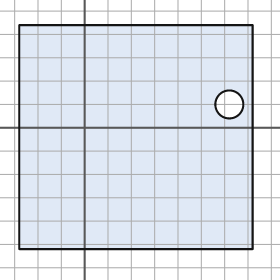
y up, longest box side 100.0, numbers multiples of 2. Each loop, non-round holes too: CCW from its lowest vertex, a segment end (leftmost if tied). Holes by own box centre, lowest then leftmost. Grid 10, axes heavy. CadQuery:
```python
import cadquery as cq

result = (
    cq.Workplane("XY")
    .moveTo(-28.0, -52.0)
    .lineTo(72.0, -52.0)
    .lineTo(72.0, 44.0)
    .lineTo(-28.0, 44.0)
    .close()
    .moveTo(62.0, 10.0)
    .circle(6.0)
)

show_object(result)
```